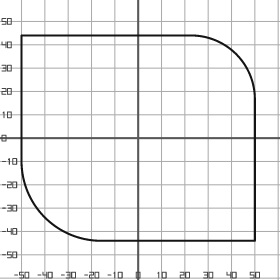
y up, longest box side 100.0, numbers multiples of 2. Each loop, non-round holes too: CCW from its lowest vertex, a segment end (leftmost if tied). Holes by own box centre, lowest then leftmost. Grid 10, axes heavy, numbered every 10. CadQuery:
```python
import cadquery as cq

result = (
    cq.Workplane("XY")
    .moveTo(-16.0, -44.0)
    .lineTo(50.0, -44.0)
    .lineTo(50.0, 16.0)
    .threePointArc((42.0, 36.0), (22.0, 44.0))
    .lineTo(-50.0, 44.0)
    .lineTo(-50.0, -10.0)
    .threePointArc((-40.0, -34.0), (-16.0, -44.0))
    .close()
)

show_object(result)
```